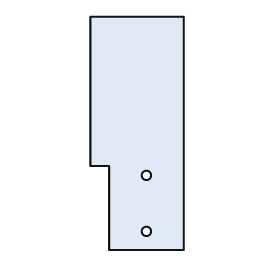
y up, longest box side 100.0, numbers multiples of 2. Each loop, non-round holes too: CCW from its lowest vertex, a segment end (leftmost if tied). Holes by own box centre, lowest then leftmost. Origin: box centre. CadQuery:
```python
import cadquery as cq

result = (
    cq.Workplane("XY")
    .moveTo(-12.0, -50.0)
    .lineTo(20.0, -50.0)
    .lineTo(20.0, 50.0)
    .lineTo(-20.0, 50.0)
    .lineTo(-20.0, -14.0)
    .lineTo(-12.0, -14.0)
    .close()
    .moveTo(4.0, -42.0)
    .circle(2.0)
    .moveTo(4.0, -18.0)
    .circle(2.0)
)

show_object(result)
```